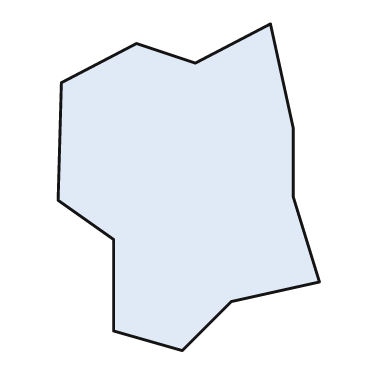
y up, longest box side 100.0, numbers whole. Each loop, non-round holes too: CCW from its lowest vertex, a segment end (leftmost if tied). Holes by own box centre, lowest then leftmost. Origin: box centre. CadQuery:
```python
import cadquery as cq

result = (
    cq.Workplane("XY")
    .moveTo(-2.0, -50.0)
    .lineTo(13.0, -35.0)
    .lineTo(40.0, -29.0)
    .lineTo(32.0, -3.0)
    .lineTo(32.0, 18.0)
    .lineTo(25.0, 50.0)
    .lineTo(2.0, 38.0)
    .lineTo(-16.0, 44.0)
    .lineTo(-39.0, 32.0)
    .lineTo(-40.0, -4.0)
    .lineTo(-23.0, -16.0)
    .lineTo(-23.0, -44.0)
    .close()
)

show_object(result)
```